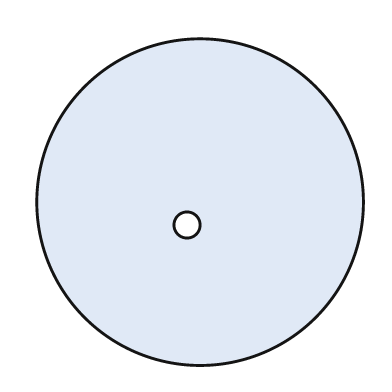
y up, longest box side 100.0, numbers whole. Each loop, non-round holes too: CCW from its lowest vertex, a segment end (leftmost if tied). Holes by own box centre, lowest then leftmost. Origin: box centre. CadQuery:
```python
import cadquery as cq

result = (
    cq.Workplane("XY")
    .moveTo(0.0, 0.0)
    .circle(50.0)
    .moveTo(-4.0, -7.0)
    .circle(4.0)
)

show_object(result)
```